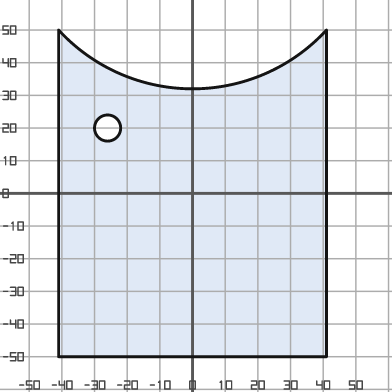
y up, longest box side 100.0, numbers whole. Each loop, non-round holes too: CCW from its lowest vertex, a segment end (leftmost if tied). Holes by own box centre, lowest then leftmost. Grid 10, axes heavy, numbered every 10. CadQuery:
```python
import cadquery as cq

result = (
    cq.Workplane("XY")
    .moveTo(-41.0, -50.0)
    .lineTo(41.0, -50.0)
    .lineTo(41.0, 50.0)
    .threePointArc((0.0, 32.0), (-41.0, 50.0))
    .close()
    .moveTo(-26.0, 20.0)
    .circle(4.0)
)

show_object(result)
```